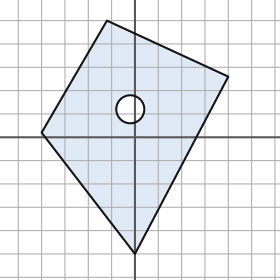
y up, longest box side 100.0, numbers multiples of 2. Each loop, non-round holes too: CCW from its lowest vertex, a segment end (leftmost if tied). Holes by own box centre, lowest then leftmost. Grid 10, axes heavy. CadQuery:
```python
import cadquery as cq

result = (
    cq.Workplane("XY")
    .moveTo(0.0, -50.0)
    .lineTo(40.0, 26.0)
    .lineTo(-12.0, 50.0)
    .lineTo(-40.0, 2.0)
    .close()
    .moveTo(-2.0, 12.0)
    .circle(6.0)
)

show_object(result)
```